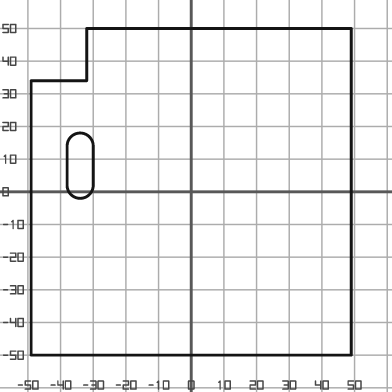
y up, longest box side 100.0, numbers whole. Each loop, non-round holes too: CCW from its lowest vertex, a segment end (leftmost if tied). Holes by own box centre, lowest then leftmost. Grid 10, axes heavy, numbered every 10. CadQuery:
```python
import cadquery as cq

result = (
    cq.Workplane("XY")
    .moveTo(-49.0, -50.0)
    .lineTo(49.0, -50.0)
    .lineTo(49.0, 50.0)
    .lineTo(-32.0, 50.0)
    .lineTo(-32.0, 34.0)
    .lineTo(-49.0, 34.0)
    .close()
    .moveTo(-38.0, 2.0)
    .threePointArc((-34.0, -2.0), (-30.0, 2.0))
    .lineTo(-30.0, 14.0)
    .threePointArc((-34.0, 18.0), (-38.0, 14.0))
    .close()
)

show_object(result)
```